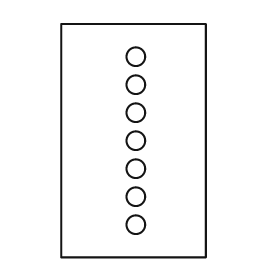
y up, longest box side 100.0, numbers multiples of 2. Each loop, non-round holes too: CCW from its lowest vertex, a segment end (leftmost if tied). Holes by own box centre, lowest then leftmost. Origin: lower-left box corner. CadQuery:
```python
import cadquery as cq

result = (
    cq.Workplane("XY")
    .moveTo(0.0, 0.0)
    .lineTo(62.0, 0.0)
    .lineTo(62.0, 100.0)
    .lineTo(0.0, 100.0)
    .close()
    .moveTo(32.0, 14.0)
    .circle(4.0)
    .moveTo(32.0, 26.0)
    .circle(4.0)
    .moveTo(32.0, 38.0)
    .circle(4.0)
    .moveTo(32.0, 50.0)
    .circle(4.0)
    .moveTo(32.0, 62.0)
    .circle(4.0)
    .moveTo(32.0, 74.0)
    .circle(4.0)
    .moveTo(32.0, 86.0)
    .circle(4.0)
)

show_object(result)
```